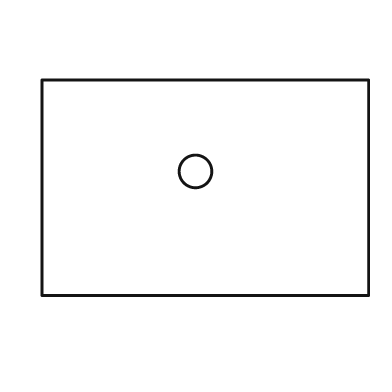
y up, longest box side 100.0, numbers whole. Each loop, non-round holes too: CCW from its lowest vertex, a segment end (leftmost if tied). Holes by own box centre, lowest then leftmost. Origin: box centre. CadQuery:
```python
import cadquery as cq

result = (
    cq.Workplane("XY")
    .moveTo(-50.0, -33.0)
    .lineTo(50.0, -33.0)
    .lineTo(50.0, 33.0)
    .lineTo(-50.0, 33.0)
    .close()
    .moveTo(-3.0, 5.0)
    .circle(5.0)
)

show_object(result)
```